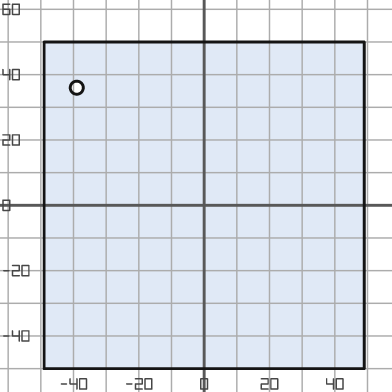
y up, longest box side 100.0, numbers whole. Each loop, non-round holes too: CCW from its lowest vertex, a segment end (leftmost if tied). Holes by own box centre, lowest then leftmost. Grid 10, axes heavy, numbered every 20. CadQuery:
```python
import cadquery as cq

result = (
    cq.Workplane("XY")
    .moveTo(-49.0, -50.0)
    .lineTo(49.0, -50.0)
    .lineTo(49.0, 50.0)
    .lineTo(-49.0, 50.0)
    .close()
    .moveTo(-39.0, 36.0)
    .circle(2.0)
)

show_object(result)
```